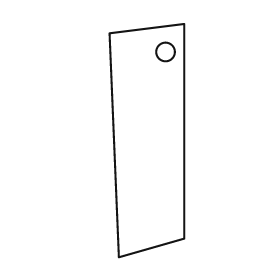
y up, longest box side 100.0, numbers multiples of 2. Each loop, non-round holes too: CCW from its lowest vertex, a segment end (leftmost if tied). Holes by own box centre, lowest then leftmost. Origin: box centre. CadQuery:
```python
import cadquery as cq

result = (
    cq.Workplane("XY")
    .moveTo(-12.0, -50.0)
    .lineTo(16.0, -42.0)
    .lineTo(16.0, 50.0)
    .lineTo(-16.0, 46.0)
    .close()
    .moveTo(8.0, 38.0)
    .circle(4.0)
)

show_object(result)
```